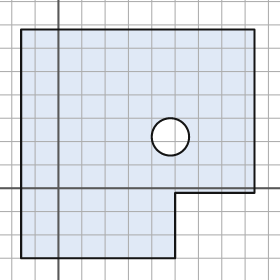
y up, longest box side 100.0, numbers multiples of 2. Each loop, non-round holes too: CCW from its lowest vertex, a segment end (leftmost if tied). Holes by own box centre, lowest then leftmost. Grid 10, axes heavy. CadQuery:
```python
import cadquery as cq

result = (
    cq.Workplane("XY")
    .moveTo(-16.0, -30.0)
    .lineTo(50.0, -30.0)
    .lineTo(50.0, -2.0)
    .lineTo(84.0, -2.0)
    .lineTo(84.0, 68.0)
    .lineTo(-16.0, 68.0)
    .close()
    .moveTo(48.0, 22.0)
    .circle(8.0)
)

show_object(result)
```